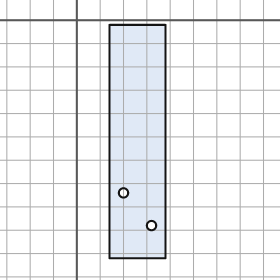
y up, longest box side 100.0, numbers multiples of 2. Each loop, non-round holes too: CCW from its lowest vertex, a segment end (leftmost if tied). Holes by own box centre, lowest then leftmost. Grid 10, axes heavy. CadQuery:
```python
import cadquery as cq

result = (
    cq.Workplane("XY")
    .moveTo(14.0, -102.0)
    .lineTo(38.0, -102.0)
    .lineTo(38.0, -2.0)
    .lineTo(14.0, -2.0)
    .close()
    .moveTo(32.0, -88.0)
    .circle(2.0)
    .moveTo(20.0, -74.0)
    .circle(2.0)
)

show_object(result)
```